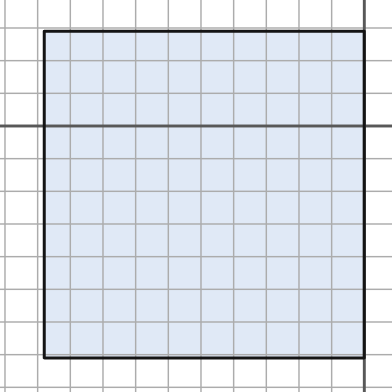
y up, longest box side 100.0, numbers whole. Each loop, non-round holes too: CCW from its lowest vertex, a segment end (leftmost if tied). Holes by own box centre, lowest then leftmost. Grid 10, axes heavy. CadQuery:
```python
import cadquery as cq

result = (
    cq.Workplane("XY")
    .moveTo(-98.0, -71.0)
    .lineTo(0.0, -71.0)
    .lineTo(0.0, 29.0)
    .lineTo(-98.0, 29.0)
    .close()
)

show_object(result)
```